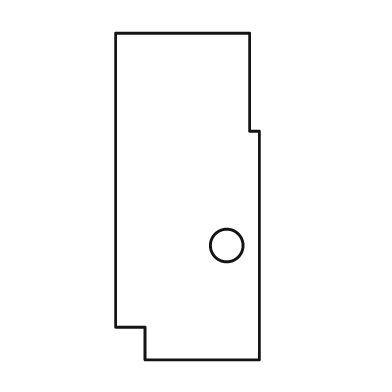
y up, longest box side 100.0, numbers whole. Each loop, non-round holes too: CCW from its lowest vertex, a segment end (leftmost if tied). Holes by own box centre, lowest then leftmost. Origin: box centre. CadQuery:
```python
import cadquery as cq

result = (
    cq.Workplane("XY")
    .moveTo(-13.0, -50.0)
    .lineTo(22.0, -50.0)
    .lineTo(22.0, 20.0)
    .lineTo(19.0, 20.0)
    .lineTo(19.0, 50.0)
    .lineTo(-22.0, 50.0)
    .lineTo(-22.0, -40.0)
    .lineTo(-13.0, -40.0)
    .close()
    .moveTo(12.0, -15.0)
    .circle(5.0)
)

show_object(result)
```